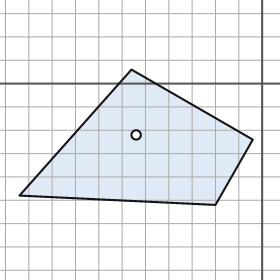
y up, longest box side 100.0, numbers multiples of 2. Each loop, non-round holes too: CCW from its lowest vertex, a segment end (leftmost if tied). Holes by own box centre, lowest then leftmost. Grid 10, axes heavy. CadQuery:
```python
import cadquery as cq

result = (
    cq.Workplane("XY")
    .moveTo(-20.0, -52.0)
    .lineTo(-4.0, -24.0)
    .lineTo(-56.0, 6.0)
    .lineTo(-104.0, -48.0)
    .close()
    .moveTo(-54.0, -22.0)
    .circle(2.0)
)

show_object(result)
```